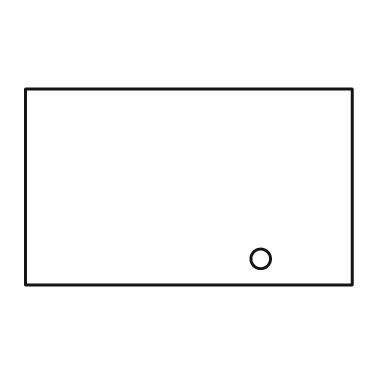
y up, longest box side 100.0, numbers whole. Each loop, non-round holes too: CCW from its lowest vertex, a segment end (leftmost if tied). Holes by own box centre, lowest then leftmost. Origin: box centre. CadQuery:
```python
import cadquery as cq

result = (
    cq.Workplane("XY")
    .moveTo(-50.0, -30.0)
    .lineTo(50.0, -30.0)
    .lineTo(50.0, 30.0)
    .lineTo(-50.0, 30.0)
    .close()
    .moveTo(22.0, -22.0)
    .circle(3.0)
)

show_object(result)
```